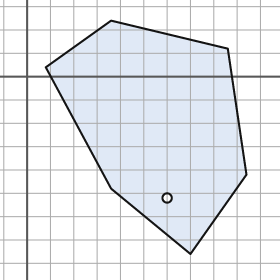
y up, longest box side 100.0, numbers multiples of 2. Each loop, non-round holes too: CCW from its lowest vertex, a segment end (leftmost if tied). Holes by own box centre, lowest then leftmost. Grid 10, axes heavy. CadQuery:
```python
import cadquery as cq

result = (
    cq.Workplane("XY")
    .moveTo(70.0, -76.0)
    .lineTo(94.0, -42.0)
    .lineTo(86.0, 12.0)
    .lineTo(36.0, 24.0)
    .lineTo(8.0, 4.0)
    .lineTo(36.0, -48.0)
    .close()
    .moveTo(60.0, -52.0)
    .circle(2.0)
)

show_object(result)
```